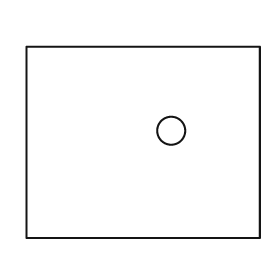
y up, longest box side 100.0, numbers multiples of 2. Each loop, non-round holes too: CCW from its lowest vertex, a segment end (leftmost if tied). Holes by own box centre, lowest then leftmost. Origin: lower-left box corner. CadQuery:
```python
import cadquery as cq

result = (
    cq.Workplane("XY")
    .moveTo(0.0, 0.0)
    .lineTo(100.0, 0.0)
    .lineTo(100.0, 82.0)
    .lineTo(0.0, 82.0)
    .close()
    .moveTo(62.0, 46.0)
    .circle(6.0)
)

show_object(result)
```